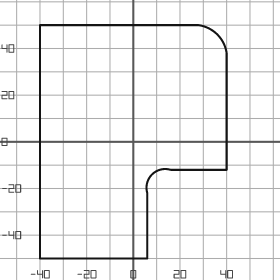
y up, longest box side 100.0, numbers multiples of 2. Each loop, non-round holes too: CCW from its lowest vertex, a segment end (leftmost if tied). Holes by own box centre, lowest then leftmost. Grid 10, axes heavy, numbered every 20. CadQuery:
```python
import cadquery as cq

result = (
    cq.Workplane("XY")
    .moveTo(-40.0, -50.0)
    .lineTo(6.0, -50.0)
    .lineTo(6.0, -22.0)
    .threePointArc((8.0, -14.0), (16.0, -12.0))
    .lineTo(40.0, -12.0)
    .lineTo(40.0, 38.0)
    .threePointArc((36.0, 46.0), (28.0, 50.0))
    .lineTo(-40.0, 50.0)
    .close()
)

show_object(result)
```